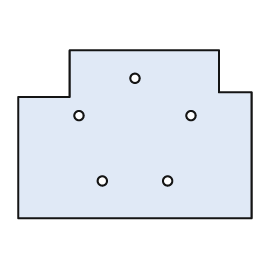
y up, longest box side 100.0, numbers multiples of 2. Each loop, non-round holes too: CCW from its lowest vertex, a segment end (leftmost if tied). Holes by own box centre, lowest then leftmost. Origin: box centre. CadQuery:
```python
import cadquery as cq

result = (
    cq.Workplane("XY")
    .moveTo(-50.0, -36.0)
    .lineTo(50.0, -36.0)
    .lineTo(50.0, 18.0)
    .lineTo(36.0, 18.0)
    .lineTo(36.0, 36.0)
    .lineTo(-28.0, 36.0)
    .lineTo(-28.0, 16.0)
    .lineTo(-50.0, 16.0)
    .close()
    .moveTo(-14.0, -20.0)
    .circle(2.0)
    .moveTo(14.0, -20.0)
    .circle(2.0)
    .moveTo(-24.0, 8.0)
    .circle(2.0)
    .moveTo(24.0, 8.0)
    .circle(2.0)
    .moveTo(0.0, 24.0)
    .circle(2.0)
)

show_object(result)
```